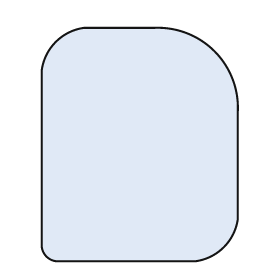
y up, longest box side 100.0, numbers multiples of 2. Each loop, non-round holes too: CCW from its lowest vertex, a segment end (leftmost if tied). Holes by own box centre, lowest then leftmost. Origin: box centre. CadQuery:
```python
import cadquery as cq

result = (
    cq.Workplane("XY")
    .moveTo(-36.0, -50.0)
    .lineTo(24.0, -50.0)
    .threePointArc((36.0, -44.0), (42.0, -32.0))
    .lineTo(42.0, 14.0)
    .threePointArc((32.0, 40.0), (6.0, 50.0))
    .lineTo(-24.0, 50.0)
    .threePointArc((-36.0, 44.0), (-42.0, 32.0))
    .lineTo(-42.0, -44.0)
    .threePointArc((-40.0, -48.0), (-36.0, -50.0))
    .close()
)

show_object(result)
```